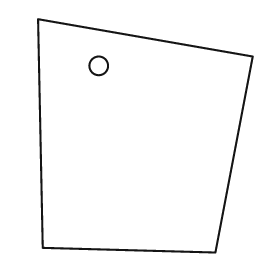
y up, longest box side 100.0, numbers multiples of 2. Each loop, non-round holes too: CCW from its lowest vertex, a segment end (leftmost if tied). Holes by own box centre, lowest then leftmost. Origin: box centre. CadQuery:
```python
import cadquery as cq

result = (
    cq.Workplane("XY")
    .moveTo(30.0, -50.0)
    .lineTo(46.0, 34.0)
    .lineTo(-46.0, 50.0)
    .lineTo(-44.0, -48.0)
    .close()
    .moveTo(-20.0, 30.0)
    .circle(4.0)
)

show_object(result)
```